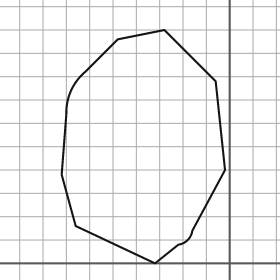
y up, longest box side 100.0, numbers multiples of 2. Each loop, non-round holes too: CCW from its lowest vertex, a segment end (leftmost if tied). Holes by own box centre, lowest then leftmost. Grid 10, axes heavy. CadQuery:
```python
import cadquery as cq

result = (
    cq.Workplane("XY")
    .moveTo(-32.0, 0.0)
    .lineTo(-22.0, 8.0)
    .threePointArc((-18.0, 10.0), (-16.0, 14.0))
    .lineTo(-2.0, 40.0)
    .lineTo(-6.0, 78.0)
    .lineTo(-28.0, 100.0)
    .lineTo(-48.0, 96.0)
    .lineTo(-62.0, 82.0)
    .threePointArc((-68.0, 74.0), (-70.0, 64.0))
    .lineTo(-72.0, 38.0)
    .lineTo(-66.0, 16.0)
    .close()
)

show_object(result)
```